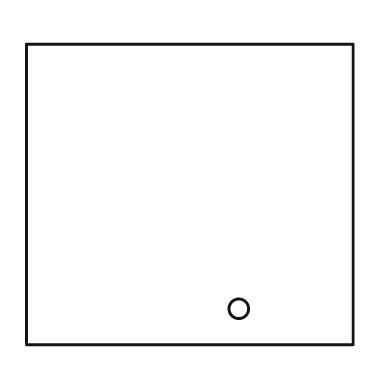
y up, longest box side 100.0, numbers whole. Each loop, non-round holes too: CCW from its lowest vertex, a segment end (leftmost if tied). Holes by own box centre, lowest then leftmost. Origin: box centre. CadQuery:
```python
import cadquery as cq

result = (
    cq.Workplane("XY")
    .moveTo(-50.0, -46.0)
    .lineTo(50.0, -46.0)
    .lineTo(50.0, 46.0)
    .lineTo(-50.0, 46.0)
    .close()
    .moveTo(15.0, -35.0)
    .circle(3.0)
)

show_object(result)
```